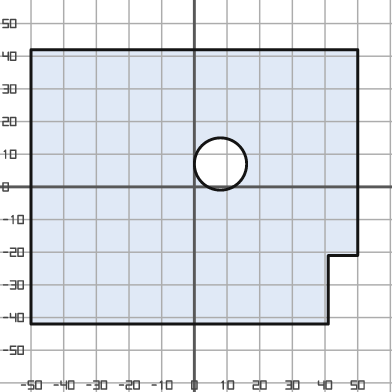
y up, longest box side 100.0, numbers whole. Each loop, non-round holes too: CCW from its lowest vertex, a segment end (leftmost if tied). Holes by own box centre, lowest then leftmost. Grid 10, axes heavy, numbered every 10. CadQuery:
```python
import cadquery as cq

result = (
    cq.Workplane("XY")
    .moveTo(-50.0, -42.0)
    .lineTo(41.0, -42.0)
    .lineTo(41.0, -21.0)
    .lineTo(50.0, -21.0)
    .lineTo(50.0, 42.0)
    .lineTo(-50.0, 42.0)
    .close()
    .moveTo(8.0, 7.0)
    .circle(8.0)
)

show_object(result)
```